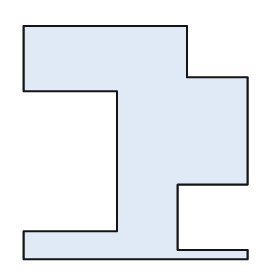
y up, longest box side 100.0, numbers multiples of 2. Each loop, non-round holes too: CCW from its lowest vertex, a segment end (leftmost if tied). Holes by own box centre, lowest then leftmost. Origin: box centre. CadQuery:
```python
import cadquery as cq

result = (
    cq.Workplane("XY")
    .moveTo(-48.0, -50.0)
    .lineTo(48.0, -50.0)
    .lineTo(48.0, -46.0)
    .lineTo(18.0, -46.0)
    .lineTo(18.0, -18.0)
    .lineTo(48.0, -18.0)
    .lineTo(48.0, 28.0)
    .lineTo(22.0, 28.0)
    .lineTo(22.0, 50.0)
    .lineTo(-48.0, 50.0)
    .lineTo(-48.0, 22.0)
    .lineTo(-8.0, 22.0)
    .lineTo(-8.0, -38.0)
    .lineTo(-48.0, -38.0)
    .close()
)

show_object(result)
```